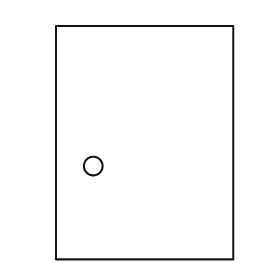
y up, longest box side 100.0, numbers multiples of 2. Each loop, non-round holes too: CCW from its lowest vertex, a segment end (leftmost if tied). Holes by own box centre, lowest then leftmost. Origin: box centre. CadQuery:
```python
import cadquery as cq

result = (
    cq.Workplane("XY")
    .moveTo(-38.0, -50.0)
    .lineTo(38.0, -50.0)
    .lineTo(38.0, 50.0)
    .lineTo(-38.0, 50.0)
    .close()
    .moveTo(-22.0, -10.0)
    .circle(4.0)
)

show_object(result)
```